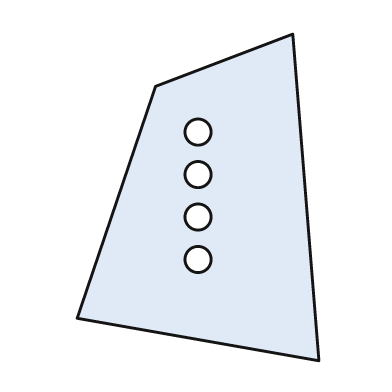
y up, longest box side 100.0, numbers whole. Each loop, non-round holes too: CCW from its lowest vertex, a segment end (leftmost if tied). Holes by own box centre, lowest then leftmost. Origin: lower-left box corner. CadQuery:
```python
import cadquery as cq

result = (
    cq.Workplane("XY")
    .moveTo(74.0, 0.0)
    .lineTo(66.0, 100.0)
    .lineTo(24.0, 84.0)
    .lineTo(0.0, 13.0)
    .close()
    .moveTo(37.0, 31.0)
    .circle(4.0)
    .moveTo(37.0, 44.0)
    .circle(4.0)
    .moveTo(37.0, 57.0)
    .circle(4.0)
    .moveTo(37.0, 70.0)
    .circle(4.0)
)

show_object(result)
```